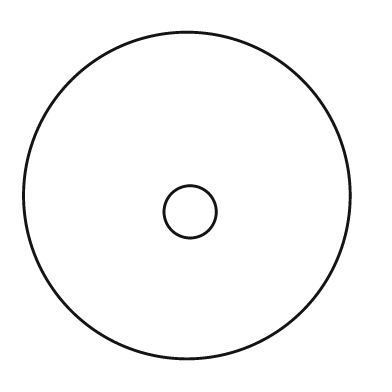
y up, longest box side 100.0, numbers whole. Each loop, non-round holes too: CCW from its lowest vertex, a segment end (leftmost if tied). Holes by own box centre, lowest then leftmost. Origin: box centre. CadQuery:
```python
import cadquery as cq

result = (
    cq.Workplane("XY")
    .moveTo(0.0, 0.0)
    .circle(50.0)
    .moveTo(1.0, -5.0)
    .circle(8.0)
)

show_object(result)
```